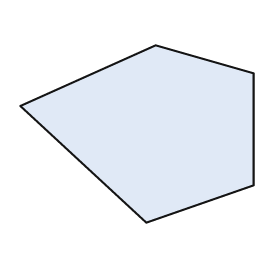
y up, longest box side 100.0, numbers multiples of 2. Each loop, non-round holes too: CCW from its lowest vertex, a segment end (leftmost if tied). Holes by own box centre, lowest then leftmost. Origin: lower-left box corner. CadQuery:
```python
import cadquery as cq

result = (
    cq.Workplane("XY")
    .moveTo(54.0, 0.0)
    .lineTo(100.0, 16.0)
    .lineTo(100.0, 64.0)
    .lineTo(58.0, 76.0)
    .lineTo(0.0, 50.0)
    .close()
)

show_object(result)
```